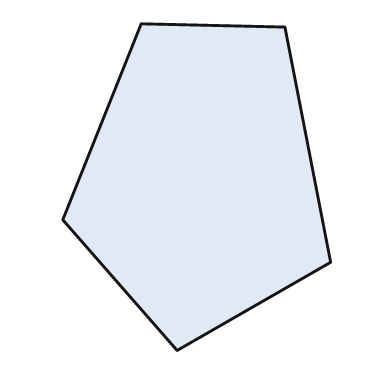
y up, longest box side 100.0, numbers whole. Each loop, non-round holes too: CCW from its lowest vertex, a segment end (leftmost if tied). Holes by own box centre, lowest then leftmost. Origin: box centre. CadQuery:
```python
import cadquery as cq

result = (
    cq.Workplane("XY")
    .moveTo(-6.0, -50.0)
    .lineTo(41.0, -23.0)
    .lineTo(27.0, 49.0)
    .lineTo(-17.0, 50.0)
    .lineTo(-41.0, -10.0)
    .close()
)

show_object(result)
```